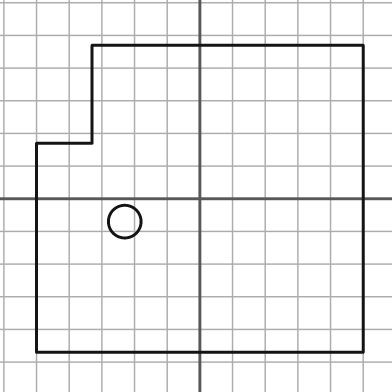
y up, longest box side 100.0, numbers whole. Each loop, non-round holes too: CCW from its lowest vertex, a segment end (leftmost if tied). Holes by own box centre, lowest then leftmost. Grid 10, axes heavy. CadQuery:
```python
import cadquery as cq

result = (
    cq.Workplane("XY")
    .moveTo(-50.0, -47.0)
    .lineTo(50.0, -47.0)
    .lineTo(50.0, 47.0)
    .lineTo(-33.0, 47.0)
    .lineTo(-33.0, 17.0)
    .lineTo(-50.0, 17.0)
    .close()
    .moveTo(-23.0, -7.0)
    .circle(5.0)
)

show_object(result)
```